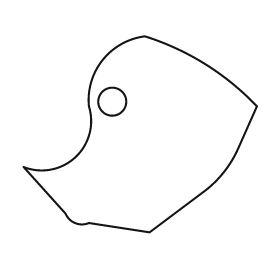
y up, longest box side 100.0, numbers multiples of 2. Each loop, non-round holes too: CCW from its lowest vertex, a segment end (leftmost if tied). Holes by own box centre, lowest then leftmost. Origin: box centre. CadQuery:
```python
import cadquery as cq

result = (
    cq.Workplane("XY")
    .moveTo(4.0, -42.0)
    .lineTo(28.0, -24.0)
    .threePointArc((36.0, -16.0), (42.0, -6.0))
    .lineTo(50.0, 12.0)
    .threePointArc((28.0, 30.0), (2.0, 42.0))
    .threePointArc((-16.0, 32.0), (-22.0, 12.0))
    .threePointArc((-28.0, -10.0), (-50.0, -14.0))
    .lineTo(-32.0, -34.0)
    .threePointArc((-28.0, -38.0), (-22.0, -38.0))
    .close()
    .moveTo(-12.0, 14.0)
    .circle(6.0)
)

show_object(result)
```